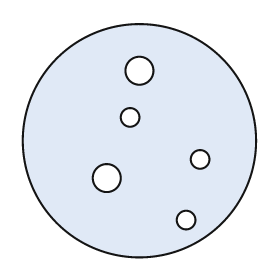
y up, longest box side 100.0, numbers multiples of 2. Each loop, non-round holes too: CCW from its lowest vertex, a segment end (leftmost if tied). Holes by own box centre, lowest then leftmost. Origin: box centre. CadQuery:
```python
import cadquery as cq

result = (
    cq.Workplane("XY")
    .moveTo(0.0, 0.0)
    .circle(50.0)
    .moveTo(20.0, -34.0)
    .circle(4.0)
    .moveTo(-14.0, -16.0)
    .circle(6.0)
    .moveTo(26.0, -8.0)
    .circle(4.0)
    .moveTo(-4.0, 10.0)
    .circle(4.0)
    .moveTo(0.0, 30.0)
    .circle(6.0)
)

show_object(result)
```